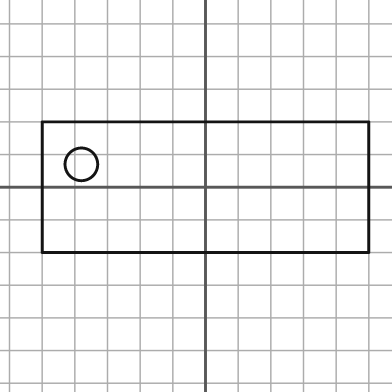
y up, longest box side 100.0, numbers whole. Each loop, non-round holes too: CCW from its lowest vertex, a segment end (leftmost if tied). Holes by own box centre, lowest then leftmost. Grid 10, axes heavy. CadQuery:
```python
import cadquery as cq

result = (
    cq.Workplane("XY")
    .moveTo(-50.0, -20.0)
    .lineTo(50.0, -20.0)
    .lineTo(50.0, 20.0)
    .lineTo(-50.0, 20.0)
    .close()
    .moveTo(-38.0, 7.0)
    .circle(5.0)
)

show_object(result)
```